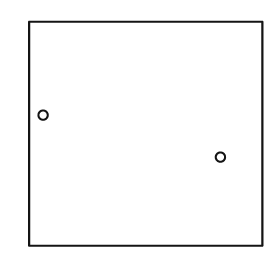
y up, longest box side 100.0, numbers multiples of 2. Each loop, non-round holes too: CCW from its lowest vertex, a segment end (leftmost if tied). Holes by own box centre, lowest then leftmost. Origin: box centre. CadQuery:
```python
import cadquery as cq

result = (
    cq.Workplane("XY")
    .moveTo(-50.0, -48.0)
    .lineTo(50.0, -48.0)
    .lineTo(50.0, 48.0)
    .lineTo(-50.0, 48.0)
    .close()
    .moveTo(32.0, -10.0)
    .circle(2.0)
    .moveTo(-44.0, 8.0)
    .circle(2.0)
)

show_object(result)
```